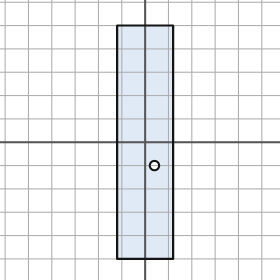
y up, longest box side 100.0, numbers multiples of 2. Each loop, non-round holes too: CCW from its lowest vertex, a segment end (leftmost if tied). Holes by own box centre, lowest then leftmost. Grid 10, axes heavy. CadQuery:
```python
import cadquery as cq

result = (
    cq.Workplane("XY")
    .moveTo(-12.0, -50.0)
    .lineTo(12.0, -50.0)
    .lineTo(12.0, 50.0)
    .lineTo(-12.0, 50.0)
    .close()
    .moveTo(4.0, -10.0)
    .circle(2.0)
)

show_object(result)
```